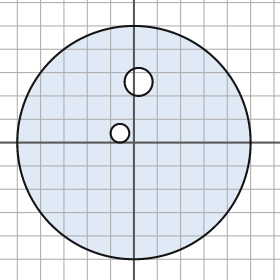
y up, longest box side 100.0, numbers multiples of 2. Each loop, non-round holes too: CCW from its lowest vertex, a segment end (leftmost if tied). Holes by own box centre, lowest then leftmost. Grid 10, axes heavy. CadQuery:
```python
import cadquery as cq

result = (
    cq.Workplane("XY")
    .moveTo(0.0, 0.0)
    .circle(50.0)
    .moveTo(-6.0, 4.0)
    .circle(4.0)
    .moveTo(2.0, 26.0)
    .circle(6.0)
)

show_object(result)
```